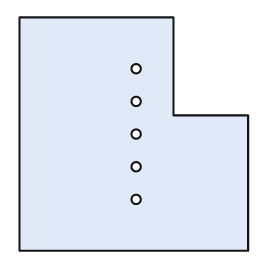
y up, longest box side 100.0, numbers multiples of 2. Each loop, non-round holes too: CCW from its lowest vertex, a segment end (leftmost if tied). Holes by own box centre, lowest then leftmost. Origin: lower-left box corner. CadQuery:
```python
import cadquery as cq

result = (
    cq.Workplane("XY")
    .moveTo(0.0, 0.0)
    .lineTo(98.0, 0.0)
    .lineTo(98.0, 58.0)
    .lineTo(66.0, 58.0)
    .lineTo(66.0, 100.0)
    .lineTo(0.0, 100.0)
    .close()
    .moveTo(50.0, 22.0)
    .circle(2.0)
    .moveTo(50.0, 36.0)
    .circle(2.0)
    .moveTo(50.0, 50.0)
    .circle(2.0)
    .moveTo(50.0, 64.0)
    .circle(2.0)
    .moveTo(50.0, 78.0)
    .circle(2.0)
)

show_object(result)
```